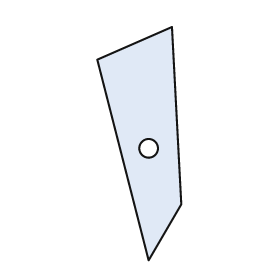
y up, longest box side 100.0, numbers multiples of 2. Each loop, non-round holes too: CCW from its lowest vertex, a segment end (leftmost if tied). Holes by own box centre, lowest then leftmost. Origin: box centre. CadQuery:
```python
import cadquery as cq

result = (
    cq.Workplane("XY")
    .moveTo(4.0, -50.0)
    .lineTo(18.0, -26.0)
    .lineTo(14.0, 50.0)
    .lineTo(-18.0, 36.0)
    .close()
    .moveTo(4.0, -2.0)
    .circle(4.0)
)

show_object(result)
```